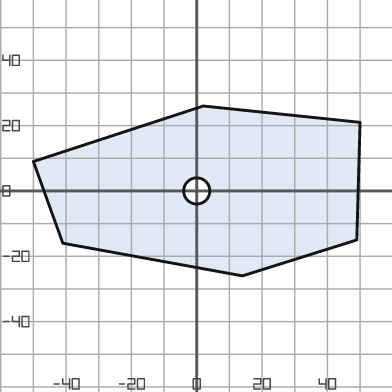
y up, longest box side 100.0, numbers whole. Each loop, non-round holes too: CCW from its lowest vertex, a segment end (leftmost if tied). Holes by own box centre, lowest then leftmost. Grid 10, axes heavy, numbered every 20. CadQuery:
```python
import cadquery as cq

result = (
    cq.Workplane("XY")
    .moveTo(14.0, -26.0)
    .lineTo(49.0, -15.0)
    .lineTo(50.0, 21.0)
    .lineTo(2.0, 26.0)
    .lineTo(-50.0, 9.0)
    .lineTo(-41.0, -16.0)
    .close()
    .moveTo(0.0, 0.0)
    .circle(4.0)
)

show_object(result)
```